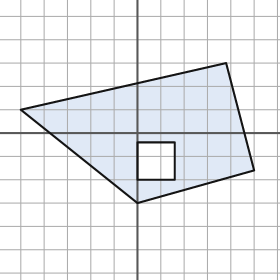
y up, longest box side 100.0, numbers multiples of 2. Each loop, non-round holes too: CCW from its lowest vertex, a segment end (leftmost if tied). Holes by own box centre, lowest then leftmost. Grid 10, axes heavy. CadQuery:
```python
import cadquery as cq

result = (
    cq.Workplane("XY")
    .moveTo(0.0, -30.0)
    .lineTo(50.0, -16.0)
    .lineTo(38.0, 30.0)
    .lineTo(-50.0, 10.0)
    .close()
    .moveTo(0.0, -20.0)
    .lineTo(16.0, -20.0)
    .lineTo(16.0, -4.0)
    .lineTo(0.0, -4.0)
    .close()
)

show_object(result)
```